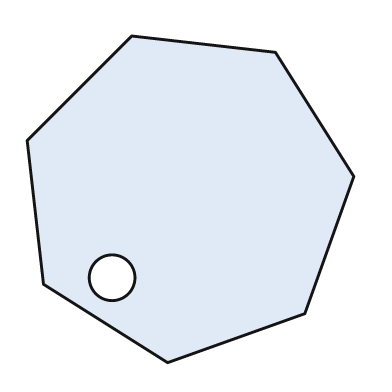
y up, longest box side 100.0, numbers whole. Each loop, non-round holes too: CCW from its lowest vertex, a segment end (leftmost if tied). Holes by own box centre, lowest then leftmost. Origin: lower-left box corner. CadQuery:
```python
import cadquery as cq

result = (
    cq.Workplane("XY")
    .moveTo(43.0, 0.0)
    .lineTo(85.0, 15.0)
    .lineTo(100.0, 57.0)
    .lineTo(76.0, 95.0)
    .lineTo(32.0, 100.0)
    .lineTo(0.0, 68.0)
    .lineTo(5.0, 24.0)
    .close()
    .moveTo(26.0, 26.0)
    .circle(7.0)
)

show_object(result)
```